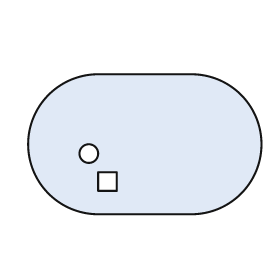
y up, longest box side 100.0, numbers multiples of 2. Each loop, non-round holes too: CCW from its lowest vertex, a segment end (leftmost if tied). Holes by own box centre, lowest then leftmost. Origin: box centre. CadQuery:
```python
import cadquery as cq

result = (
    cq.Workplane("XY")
    .moveTo(-20.0, -30.0)
    .lineTo(20.0, -30.0)
    .threePointArc((50.0, 0.0), (20.0, 30.0))
    .lineTo(-20.0, 30.0)
    .threePointArc((-50.0, 0.0), (-20.0, -30.0))
    .close()
    .moveTo(-20.0, -20.0)
    .lineTo(-12.0, -20.0)
    .lineTo(-12.0, -12.0)
    .lineTo(-20.0, -12.0)
    .close()
    .moveTo(-24.0, -4.0)
    .circle(4.0)
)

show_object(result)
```